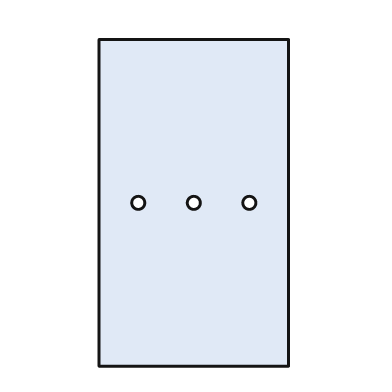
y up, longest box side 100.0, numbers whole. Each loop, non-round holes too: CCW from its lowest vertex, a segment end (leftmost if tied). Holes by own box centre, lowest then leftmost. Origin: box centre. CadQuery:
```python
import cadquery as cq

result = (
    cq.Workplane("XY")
    .moveTo(-29.0, -50.0)
    .lineTo(29.0, -50.0)
    .lineTo(29.0, 50.0)
    .lineTo(-29.0, 50.0)
    .close()
    .moveTo(-17.0, 0.0)
    .circle(2.0)
    .moveTo(0.0, 0.0)
    .circle(2.0)
    .moveTo(17.0, 0.0)
    .circle(2.0)
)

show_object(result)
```